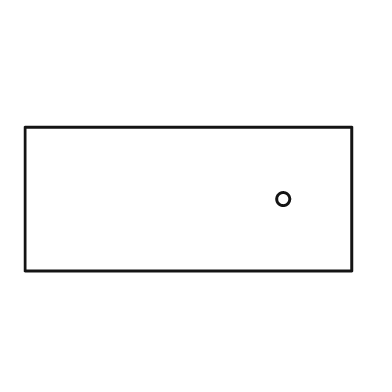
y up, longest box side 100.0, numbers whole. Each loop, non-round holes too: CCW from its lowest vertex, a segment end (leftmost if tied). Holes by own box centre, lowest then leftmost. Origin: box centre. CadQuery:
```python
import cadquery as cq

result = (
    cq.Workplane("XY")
    .moveTo(-50.0, -22.0)
    .lineTo(50.0, -22.0)
    .lineTo(50.0, 22.0)
    .lineTo(-50.0, 22.0)
    .close()
    .moveTo(29.0, 0.0)
    .circle(2.0)
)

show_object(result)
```